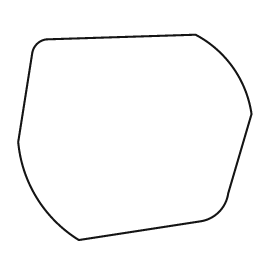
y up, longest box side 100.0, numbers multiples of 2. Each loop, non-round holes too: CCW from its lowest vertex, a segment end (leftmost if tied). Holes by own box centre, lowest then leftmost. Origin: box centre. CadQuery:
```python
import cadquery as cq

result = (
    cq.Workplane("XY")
    .moveTo(-24.0, -44.0)
    .lineTo(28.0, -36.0)
    .threePointArc((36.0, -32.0), (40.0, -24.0))
    .lineTo(50.0, 10.0)
    .threePointArc((42.0, 30.0), (26.0, 44.0))
    .lineTo(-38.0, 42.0)
    .threePointArc((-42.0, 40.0), (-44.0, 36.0))
    .lineTo(-50.0, -2.0)
    .threePointArc((-42.0, -26.0), (-24.0, -44.0))
    .close()
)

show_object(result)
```